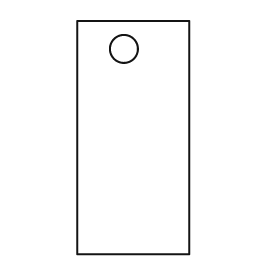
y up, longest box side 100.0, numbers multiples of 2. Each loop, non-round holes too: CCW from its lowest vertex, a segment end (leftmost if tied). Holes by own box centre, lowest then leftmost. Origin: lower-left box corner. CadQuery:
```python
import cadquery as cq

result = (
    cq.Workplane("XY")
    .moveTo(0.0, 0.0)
    .lineTo(48.0, 0.0)
    .lineTo(48.0, 100.0)
    .lineTo(0.0, 100.0)
    .close()
    .moveTo(20.0, 88.0)
    .circle(6.0)
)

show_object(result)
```